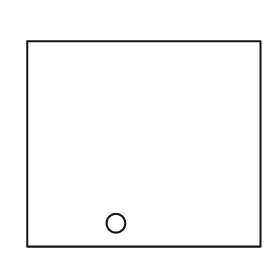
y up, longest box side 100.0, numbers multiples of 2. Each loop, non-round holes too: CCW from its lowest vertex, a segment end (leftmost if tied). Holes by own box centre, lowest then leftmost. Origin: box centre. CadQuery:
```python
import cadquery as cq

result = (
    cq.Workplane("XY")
    .moveTo(-50.0, -44.0)
    .lineTo(50.0, -44.0)
    .lineTo(50.0, 44.0)
    .lineTo(-50.0, 44.0)
    .close()
    .moveTo(-12.0, -34.0)
    .circle(4.0)
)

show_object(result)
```